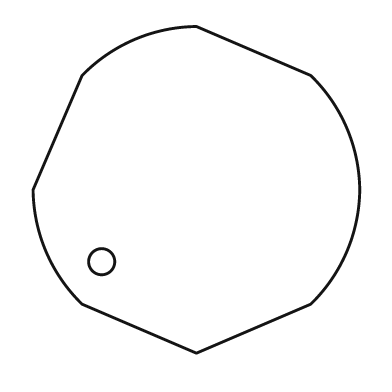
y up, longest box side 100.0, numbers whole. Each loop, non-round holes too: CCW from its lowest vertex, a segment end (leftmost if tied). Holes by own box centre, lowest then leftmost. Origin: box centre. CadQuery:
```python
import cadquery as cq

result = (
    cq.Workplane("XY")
    .moveTo(0.0, -50.0)
    .lineTo(35.0, -35.0)
    .threePointArc((46.0, -19.0), (50.0, 0.0))
    .threePointArc((46.0, 19.0), (35.0, 35.0))
    .lineTo(0.0, 50.0)
    .threePointArc((-19.0, 46.0), (-35.0, 35.0))
    .lineTo(-50.0, 0.0)
    .threePointArc((-46.0, -19.0), (-35.0, -35.0))
    .close()
    .moveTo(-29.0, -22.0)
    .circle(4.0)
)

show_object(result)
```